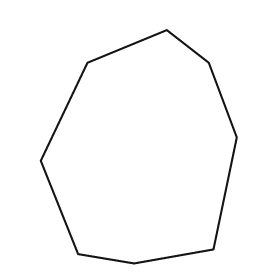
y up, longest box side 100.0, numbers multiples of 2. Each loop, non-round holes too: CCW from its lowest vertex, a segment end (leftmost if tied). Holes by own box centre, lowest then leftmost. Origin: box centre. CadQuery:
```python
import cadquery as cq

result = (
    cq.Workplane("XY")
    .moveTo(-2.0, -50.0)
    .lineTo(32.0, -44.0)
    .lineTo(42.0, 4.0)
    .lineTo(30.0, 36.0)
    .lineTo(12.0, 50.0)
    .lineTo(-22.0, 36.0)
    .lineTo(-42.0, -6.0)
    .lineTo(-26.0, -46.0)
    .close()
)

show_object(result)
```